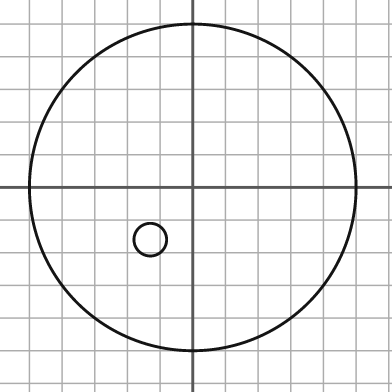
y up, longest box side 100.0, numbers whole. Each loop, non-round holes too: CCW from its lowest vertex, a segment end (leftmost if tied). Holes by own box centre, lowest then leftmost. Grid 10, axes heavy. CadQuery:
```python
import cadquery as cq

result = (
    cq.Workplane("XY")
    .moveTo(0.0, 0.0)
    .circle(50.0)
    .moveTo(-13.0, -16.0)
    .circle(5.0)
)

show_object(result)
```